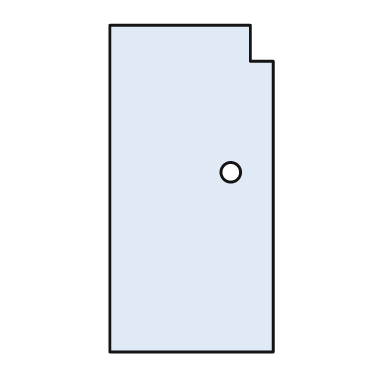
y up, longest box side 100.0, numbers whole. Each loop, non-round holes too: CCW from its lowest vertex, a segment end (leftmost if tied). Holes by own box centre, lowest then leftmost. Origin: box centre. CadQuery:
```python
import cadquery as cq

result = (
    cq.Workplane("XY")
    .moveTo(-25.0, -50.0)
    .lineTo(25.0, -50.0)
    .lineTo(25.0, 39.0)
    .lineTo(18.0, 39.0)
    .lineTo(18.0, 50.0)
    .lineTo(-25.0, 50.0)
    .close()
    .moveTo(12.0, 5.0)
    .circle(3.0)
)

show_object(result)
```